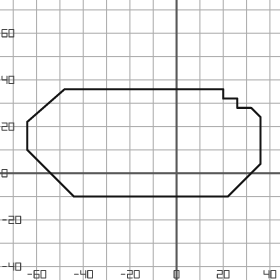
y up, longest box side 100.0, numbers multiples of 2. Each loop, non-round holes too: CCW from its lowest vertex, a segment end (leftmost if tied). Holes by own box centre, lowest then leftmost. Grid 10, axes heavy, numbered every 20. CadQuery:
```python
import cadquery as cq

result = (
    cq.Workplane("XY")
    .moveTo(-44.0, -10.0)
    .lineTo(22.0, -10.0)
    .lineTo(36.0, 4.0)
    .lineTo(36.0, 24.0)
    .lineTo(32.0, 28.0)
    .lineTo(26.0, 28.0)
    .lineTo(26.0, 32.0)
    .lineTo(20.0, 32.0)
    .lineTo(20.0, 36.0)
    .lineTo(-48.0, 36.0)
    .lineTo(-64.0, 22.0)
    .lineTo(-64.0, 10.0)
    .close()
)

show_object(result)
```